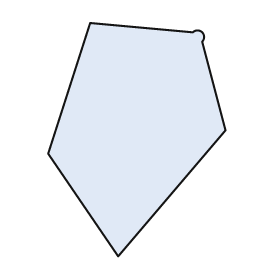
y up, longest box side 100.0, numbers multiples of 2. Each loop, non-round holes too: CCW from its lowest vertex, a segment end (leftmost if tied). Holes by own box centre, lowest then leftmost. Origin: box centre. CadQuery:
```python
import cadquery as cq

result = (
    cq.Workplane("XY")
    .moveTo(-8.0, -50.0)
    .lineTo(38.0, 4.0)
    .lineTo(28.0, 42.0)
    .threePointArc((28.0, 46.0), (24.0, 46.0))
    .lineTo(-20.0, 50.0)
    .lineTo(-38.0, -6.0)
    .close()
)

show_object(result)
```